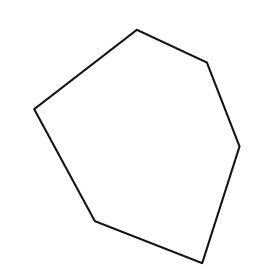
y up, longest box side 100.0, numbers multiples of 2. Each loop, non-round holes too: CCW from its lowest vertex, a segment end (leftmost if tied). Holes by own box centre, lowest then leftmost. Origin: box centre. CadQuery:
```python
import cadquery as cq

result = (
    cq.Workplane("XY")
    .moveTo(28.0, -50.0)
    .lineTo(44.0, 0.0)
    .lineTo(30.0, 36.0)
    .lineTo(0.0, 50.0)
    .lineTo(-44.0, 16.0)
    .lineTo(-18.0, -32.0)
    .close()
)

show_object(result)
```